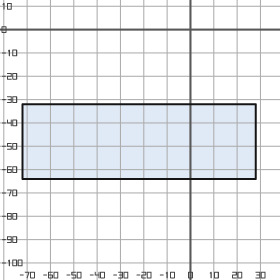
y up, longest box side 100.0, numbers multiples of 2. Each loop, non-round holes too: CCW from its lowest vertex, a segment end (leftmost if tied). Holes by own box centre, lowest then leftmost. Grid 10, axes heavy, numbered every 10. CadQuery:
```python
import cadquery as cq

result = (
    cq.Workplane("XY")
    .moveTo(-72.0, -64.0)
    .lineTo(28.0, -64.0)
    .lineTo(28.0, -32.0)
    .lineTo(-72.0, -32.0)
    .close()
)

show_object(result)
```